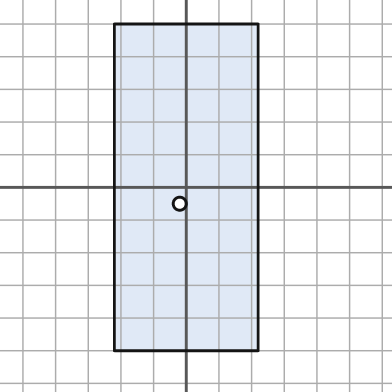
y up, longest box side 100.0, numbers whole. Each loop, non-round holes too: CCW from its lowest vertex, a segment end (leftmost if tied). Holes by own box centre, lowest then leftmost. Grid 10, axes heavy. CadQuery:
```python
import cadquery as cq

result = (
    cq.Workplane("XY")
    .moveTo(-22.0, -50.0)
    .lineTo(22.0, -50.0)
    .lineTo(22.0, 50.0)
    .lineTo(-22.0, 50.0)
    .close()
    .moveTo(-2.0, -5.0)
    .circle(2.0)
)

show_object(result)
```